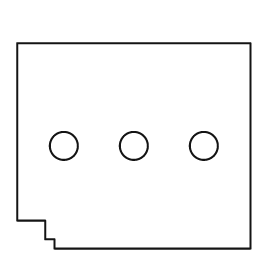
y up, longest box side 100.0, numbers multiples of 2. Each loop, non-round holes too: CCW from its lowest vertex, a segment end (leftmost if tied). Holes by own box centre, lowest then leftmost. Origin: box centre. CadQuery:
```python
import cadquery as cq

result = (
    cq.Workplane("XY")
    .moveTo(-34.0, -44.0)
    .lineTo(50.0, -44.0)
    .lineTo(50.0, 44.0)
    .lineTo(-50.0, 44.0)
    .lineTo(-50.0, -32.0)
    .lineTo(-38.0, -32.0)
    .lineTo(-38.0, -40.0)
    .lineTo(-34.0, -40.0)
    .close()
    .moveTo(-30.0, 0.0)
    .circle(6.0)
    .moveTo(0.0, 0.0)
    .circle(6.0)
    .moveTo(30.0, 0.0)
    .circle(6.0)
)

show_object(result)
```